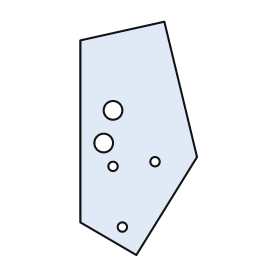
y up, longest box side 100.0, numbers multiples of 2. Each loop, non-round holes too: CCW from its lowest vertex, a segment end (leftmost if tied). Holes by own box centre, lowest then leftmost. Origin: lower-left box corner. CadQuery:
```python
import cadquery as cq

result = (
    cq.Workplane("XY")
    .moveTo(24.0, 0.0)
    .lineTo(50.0, 42.0)
    .lineTo(36.0, 100.0)
    .lineTo(0.0, 92.0)
    .lineTo(0.0, 14.0)
    .close()
    .moveTo(18.0, 12.0)
    .circle(2.0)
    .moveTo(14.0, 38.0)
    .circle(2.0)
    .moveTo(32.0, 40.0)
    .circle(2.0)
    .moveTo(10.0, 48.0)
    .circle(4.0)
    .moveTo(14.0, 62.0)
    .circle(4.0)
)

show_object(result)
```